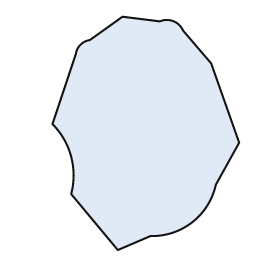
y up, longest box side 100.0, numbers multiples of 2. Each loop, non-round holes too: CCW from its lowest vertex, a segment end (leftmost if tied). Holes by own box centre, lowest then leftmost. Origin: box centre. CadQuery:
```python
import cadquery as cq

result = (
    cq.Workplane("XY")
    .moveTo(-12.0, -50.0)
    .lineTo(2.0, -44.0)
    .threePointArc((20.0, -38.0), (30.0, -22.0))
    .lineTo(40.0, -4.0)
    .lineTo(28.0, 30.0)
    .lineTo(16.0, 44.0)
    .threePointArc((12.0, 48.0), (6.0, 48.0))
    .lineTo(-10.0, 50.0)
    .lineTo(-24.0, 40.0)
    .threePointArc((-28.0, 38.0), (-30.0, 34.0))
    .lineTo(-40.0, 4.0)
    .threePointArc((-32.0, -10.0), (-32.0, -26.0))
    .close()
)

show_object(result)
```